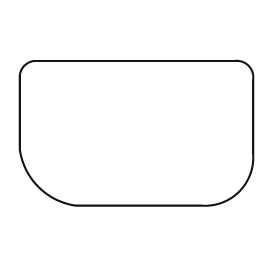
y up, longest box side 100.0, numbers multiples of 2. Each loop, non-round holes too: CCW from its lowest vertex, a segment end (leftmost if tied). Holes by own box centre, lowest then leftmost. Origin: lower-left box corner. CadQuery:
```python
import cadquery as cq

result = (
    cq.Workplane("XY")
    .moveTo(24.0, 0.0)
    .lineTo(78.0, 0.0)
    .threePointArc((94.0, 6.0), (100.0, 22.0))
    .lineTo(100.0, 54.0)
    .threePointArc((98.0, 60.0), (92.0, 62.0))
    .lineTo(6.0, 62.0)
    .threePointArc((2.0, 60.0), (0.0, 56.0))
    .lineTo(0.0, 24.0)
    .threePointArc((8.0, 8.0), (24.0, 0.0))
    .close()
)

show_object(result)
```